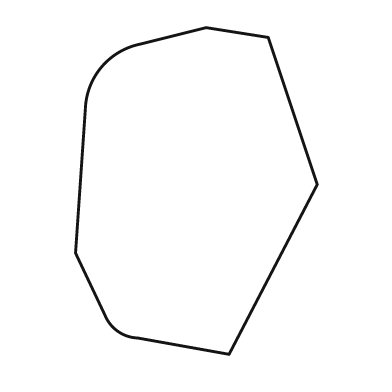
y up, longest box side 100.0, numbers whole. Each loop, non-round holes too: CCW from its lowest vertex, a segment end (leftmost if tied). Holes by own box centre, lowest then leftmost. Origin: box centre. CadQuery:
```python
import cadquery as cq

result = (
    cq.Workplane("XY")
    .moveTo(10.0, -50.0)
    .lineTo(37.0, 2.0)
    .lineTo(22.0, 47.0)
    .lineTo(3.0, 50.0)
    .lineTo(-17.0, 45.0)
    .threePointArc((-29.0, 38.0), (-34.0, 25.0))
    .lineTo(-37.0, -19.0)
    .lineTo(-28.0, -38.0)
    .threePointArc((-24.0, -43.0), (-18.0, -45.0))
    .close()
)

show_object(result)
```